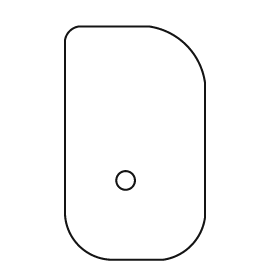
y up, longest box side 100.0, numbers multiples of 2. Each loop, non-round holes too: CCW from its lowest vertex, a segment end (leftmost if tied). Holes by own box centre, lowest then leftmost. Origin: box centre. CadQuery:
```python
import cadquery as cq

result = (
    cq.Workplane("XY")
    .moveTo(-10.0, -50.0)
    .lineTo(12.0, -50.0)
    .threePointArc((24.0, -44.0), (30.0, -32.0))
    .lineTo(30.0, 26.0)
    .threePointArc((22.0, 42.0), (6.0, 50.0))
    .lineTo(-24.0, 50.0)
    .threePointArc((-28.0, 48.0), (-30.0, 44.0))
    .lineTo(-30.0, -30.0)
    .threePointArc((-24.0, -44.0), (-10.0, -50.0))
    .close()
    .moveTo(-4.0, -16.0)
    .circle(4.0)
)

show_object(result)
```